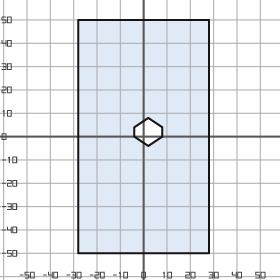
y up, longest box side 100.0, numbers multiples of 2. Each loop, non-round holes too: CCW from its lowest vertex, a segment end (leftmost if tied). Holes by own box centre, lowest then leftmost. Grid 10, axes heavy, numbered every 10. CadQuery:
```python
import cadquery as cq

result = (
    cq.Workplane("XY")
    .moveTo(-28.0, -50.0)
    .lineTo(28.0, -50.0)
    .lineTo(28.0, 50.0)
    .lineTo(-28.0, 50.0)
    .close()
    .moveTo(2.0, -4.0)
    .lineTo(8.0, 0.0)
    .lineTo(8.0, 4.0)
    .lineTo(2.0, 8.0)
    .lineTo(-4.0, 4.0)
    .lineTo(-4.0, 0.0)
    .close()
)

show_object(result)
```